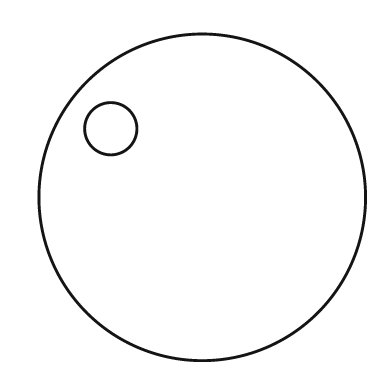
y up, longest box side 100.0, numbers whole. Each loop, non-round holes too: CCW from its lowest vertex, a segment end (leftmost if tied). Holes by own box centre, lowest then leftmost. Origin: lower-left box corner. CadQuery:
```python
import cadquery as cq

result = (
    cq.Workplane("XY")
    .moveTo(50.0, 50.0)
    .circle(50.0)
    .moveTo(22.0, 71.0)
    .circle(8.0)
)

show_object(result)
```